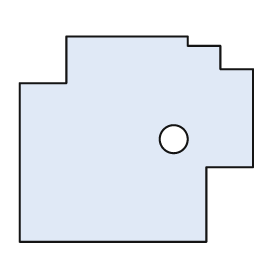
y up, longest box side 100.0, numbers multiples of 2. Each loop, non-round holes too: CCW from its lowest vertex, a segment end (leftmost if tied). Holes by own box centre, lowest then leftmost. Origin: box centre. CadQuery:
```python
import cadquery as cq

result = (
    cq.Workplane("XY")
    .moveTo(-50.0, -44.0)
    .lineTo(30.0, -44.0)
    .lineTo(30.0, -12.0)
    .lineTo(50.0, -12.0)
    .lineTo(50.0, 30.0)
    .lineTo(36.0, 30.0)
    .lineTo(36.0, 40.0)
    .lineTo(22.0, 40.0)
    .lineTo(22.0, 44.0)
    .lineTo(-30.0, 44.0)
    .lineTo(-30.0, 24.0)
    .lineTo(-50.0, 24.0)
    .close()
    .moveTo(16.0, 0.0)
    .circle(6.0)
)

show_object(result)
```